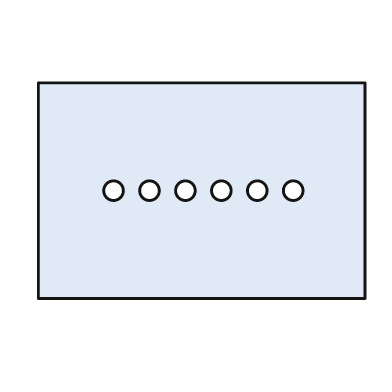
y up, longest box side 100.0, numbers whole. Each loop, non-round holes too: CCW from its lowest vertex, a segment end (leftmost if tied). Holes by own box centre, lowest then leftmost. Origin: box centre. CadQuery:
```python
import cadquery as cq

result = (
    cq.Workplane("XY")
    .moveTo(-50.0, -33.0)
    .lineTo(50.0, -33.0)
    .lineTo(50.0, 33.0)
    .lineTo(-50.0, 33.0)
    .close()
    .moveTo(-27.0, 0.0)
    .circle(3.0)
    .moveTo(-16.0, 0.0)
    .circle(3.0)
    .moveTo(-5.0, 0.0)
    .circle(3.0)
    .moveTo(6.0, 0.0)
    .circle(3.0)
    .moveTo(17.0, 0.0)
    .circle(3.0)
    .moveTo(28.0, 0.0)
    .circle(3.0)
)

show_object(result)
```